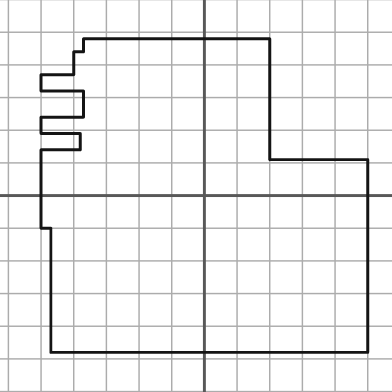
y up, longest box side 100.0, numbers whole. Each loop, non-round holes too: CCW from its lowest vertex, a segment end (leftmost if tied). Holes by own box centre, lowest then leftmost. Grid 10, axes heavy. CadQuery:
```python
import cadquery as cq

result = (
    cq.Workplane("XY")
    .moveTo(-47.0, -48.0)
    .lineTo(50.0, -48.0)
    .lineTo(50.0, 11.0)
    .lineTo(20.0, 11.0)
    .lineTo(20.0, 48.0)
    .lineTo(-37.0, 48.0)
    .lineTo(-37.0, 44.0)
    .lineTo(-40.0, 44.0)
    .lineTo(-40.0, 37.0)
    .lineTo(-50.0, 37.0)
    .lineTo(-50.0, 32.0)
    .lineTo(-37.0, 32.0)
    .lineTo(-37.0, 24.0)
    .lineTo(-50.0, 24.0)
    .lineTo(-50.0, 19.0)
    .lineTo(-38.0, 19.0)
    .lineTo(-38.0, 14.0)
    .lineTo(-50.0, 14.0)
    .lineTo(-50.0, -10.0)
    .lineTo(-47.0, -10.0)
    .close()
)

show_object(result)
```